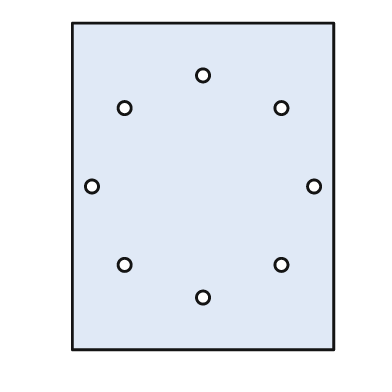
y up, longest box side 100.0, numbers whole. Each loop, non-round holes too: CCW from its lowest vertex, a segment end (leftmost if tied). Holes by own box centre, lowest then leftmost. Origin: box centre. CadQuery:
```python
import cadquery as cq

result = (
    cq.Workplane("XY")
    .moveTo(-40.0, -50.0)
    .lineTo(40.0, -50.0)
    .lineTo(40.0, 50.0)
    .lineTo(-40.0, 50.0)
    .close()
    .moveTo(0.0, -34.0)
    .circle(2.0)
    .moveTo(-24.0, -24.0)
    .circle(2.0)
    .moveTo(24.0, -24.0)
    .circle(2.0)
    .moveTo(-34.0, 0.0)
    .circle(2.0)
    .moveTo(34.0, 0.0)
    .circle(2.0)
    .moveTo(-24.0, 24.0)
    .circle(2.0)
    .moveTo(24.0, 24.0)
    .circle(2.0)
    .moveTo(0.0, 34.0)
    .circle(2.0)
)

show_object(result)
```